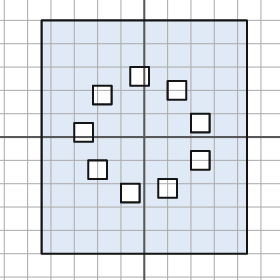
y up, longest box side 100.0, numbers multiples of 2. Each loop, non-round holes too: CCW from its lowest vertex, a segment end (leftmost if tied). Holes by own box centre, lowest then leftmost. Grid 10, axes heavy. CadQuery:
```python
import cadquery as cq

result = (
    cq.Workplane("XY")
    .moveTo(-44.0, -50.0)
    .lineTo(44.0, -50.0)
    .lineTo(44.0, 50.0)
    .lineTo(-44.0, 50.0)
    .close()
    .moveTo(-10.0, -28.0)
    .lineTo(-2.0, -28.0)
    .lineTo(-2.0, -20.0)
    .lineTo(-10.0, -20.0)
    .close()
    .moveTo(6.0, -26.0)
    .lineTo(14.0, -26.0)
    .lineTo(14.0, -18.0)
    .lineTo(6.0, -18.0)
    .close()
    .moveTo(-24.0, -18.0)
    .lineTo(-16.0, -18.0)
    .lineTo(-16.0, -10.0)
    .lineTo(-24.0, -10.0)
    .close()
    .moveTo(20.0, -14.0)
    .lineTo(28.0, -14.0)
    .lineTo(28.0, -6.0)
    .lineTo(20.0, -6.0)
    .close()
    .moveTo(-30.0, -2.0)
    .lineTo(-22.0, -2.0)
    .lineTo(-22.0, 6.0)
    .lineTo(-30.0, 6.0)
    .close()
    .moveTo(20.0, 2.0)
    .lineTo(28.0, 2.0)
    .lineTo(28.0, 10.0)
    .lineTo(20.0, 10.0)
    .close()
    .moveTo(-22.0, 14.0)
    .lineTo(-14.0, 14.0)
    .lineTo(-14.0, 22.0)
    .lineTo(-22.0, 22.0)
    .close()
    .moveTo(10.0, 16.0)
    .lineTo(18.0, 16.0)
    .lineTo(18.0, 24.0)
    .lineTo(10.0, 24.0)
    .close()
    .moveTo(-6.0, 22.0)
    .lineTo(2.0, 22.0)
    .lineTo(2.0, 30.0)
    .lineTo(-6.0, 30.0)
    .close()
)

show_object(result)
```